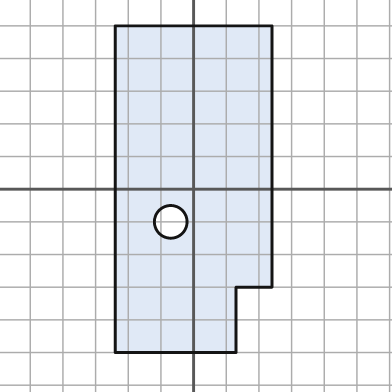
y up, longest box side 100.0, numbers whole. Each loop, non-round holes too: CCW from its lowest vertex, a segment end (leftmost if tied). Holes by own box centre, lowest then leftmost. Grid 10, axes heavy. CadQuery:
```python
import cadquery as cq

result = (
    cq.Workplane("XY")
    .moveTo(-24.0, -50.0)
    .lineTo(13.0, -50.0)
    .lineTo(13.0, -30.0)
    .lineTo(24.0, -30.0)
    .lineTo(24.0, 50.0)
    .lineTo(-24.0, 50.0)
    .close()
    .moveTo(-7.0, -10.0)
    .circle(5.0)
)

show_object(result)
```